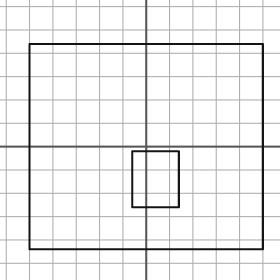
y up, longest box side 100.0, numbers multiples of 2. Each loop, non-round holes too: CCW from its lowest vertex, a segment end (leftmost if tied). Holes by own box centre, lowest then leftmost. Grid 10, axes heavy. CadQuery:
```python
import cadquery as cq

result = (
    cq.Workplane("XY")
    .moveTo(-50.0, -44.0)
    .lineTo(50.0, -44.0)
    .lineTo(50.0, 44.0)
    .lineTo(-50.0, 44.0)
    .close()
    .moveTo(-6.0, -26.0)
    .lineTo(14.0, -26.0)
    .lineTo(14.0, -2.0)
    .lineTo(-6.0, -2.0)
    .close()
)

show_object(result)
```